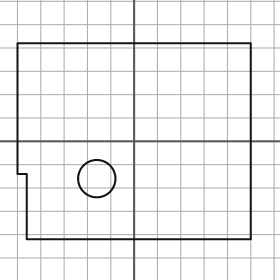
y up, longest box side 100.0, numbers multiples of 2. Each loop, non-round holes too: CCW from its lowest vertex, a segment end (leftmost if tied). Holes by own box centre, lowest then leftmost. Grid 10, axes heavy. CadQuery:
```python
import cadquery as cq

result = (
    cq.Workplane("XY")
    .moveTo(-46.0, -42.0)
    .lineTo(50.0, -42.0)
    .lineTo(50.0, 42.0)
    .lineTo(-50.0, 42.0)
    .lineTo(-50.0, -14.0)
    .lineTo(-46.0, -14.0)
    .close()
    .moveTo(-16.0, -16.0)
    .circle(8.0)
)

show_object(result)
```